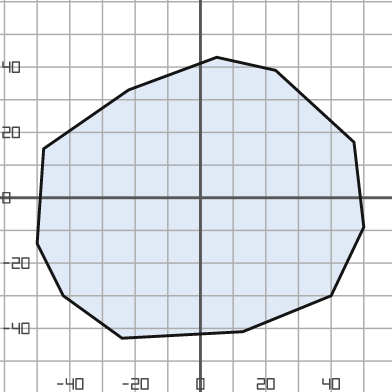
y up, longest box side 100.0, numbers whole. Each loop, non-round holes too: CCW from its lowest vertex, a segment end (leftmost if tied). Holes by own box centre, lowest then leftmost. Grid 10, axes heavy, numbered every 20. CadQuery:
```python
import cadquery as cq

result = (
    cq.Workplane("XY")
    .moveTo(-24.0, -43.0)
    .lineTo(13.0, -41.0)
    .lineTo(40.0, -30.0)
    .lineTo(50.0, -9.0)
    .lineTo(47.0, 17.0)
    .lineTo(23.0, 39.0)
    .lineTo(5.0, 43.0)
    .lineTo(-22.0, 33.0)
    .lineTo(-48.0, 15.0)
    .lineTo(-50.0, -14.0)
    .lineTo(-42.0, -30.0)
    .close()
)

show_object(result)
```